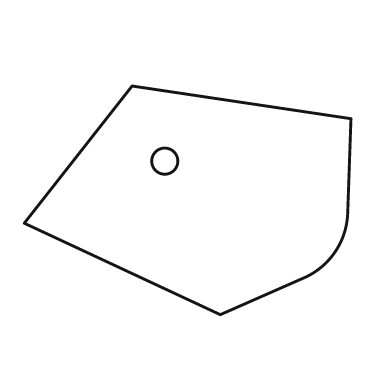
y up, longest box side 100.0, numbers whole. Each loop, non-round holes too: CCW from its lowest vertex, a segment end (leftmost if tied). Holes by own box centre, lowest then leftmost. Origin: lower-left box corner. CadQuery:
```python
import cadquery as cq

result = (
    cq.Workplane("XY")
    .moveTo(60.0, 0.0)
    .lineTo(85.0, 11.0)
    .threePointArc((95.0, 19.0), (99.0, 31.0))
    .lineTo(100.0, 60.0)
    .lineTo(33.0, 70.0)
    .lineTo(0.0, 28.0)
    .close()
    .moveTo(43.0, 47.0)
    .circle(4.0)
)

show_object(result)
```